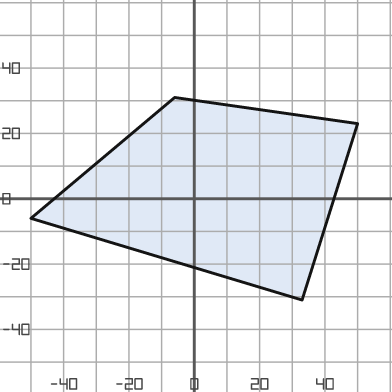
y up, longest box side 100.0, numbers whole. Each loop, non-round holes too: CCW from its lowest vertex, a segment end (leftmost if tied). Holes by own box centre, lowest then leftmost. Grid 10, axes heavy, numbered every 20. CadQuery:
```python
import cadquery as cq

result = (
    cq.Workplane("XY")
    .moveTo(33.0, -31.0)
    .lineTo(50.0, 23.0)
    .lineTo(-6.0, 31.0)
    .lineTo(-50.0, -6.0)
    .close()
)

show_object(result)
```